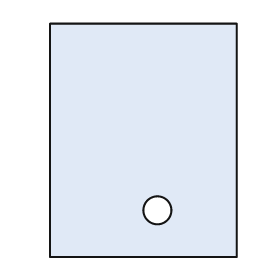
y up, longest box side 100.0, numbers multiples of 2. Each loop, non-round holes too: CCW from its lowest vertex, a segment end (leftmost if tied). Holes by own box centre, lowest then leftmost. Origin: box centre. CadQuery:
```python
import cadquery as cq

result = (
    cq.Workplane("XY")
    .moveTo(-40.0, -50.0)
    .lineTo(40.0, -50.0)
    .lineTo(40.0, 50.0)
    .lineTo(-40.0, 50.0)
    .close()
    .moveTo(6.0, -30.0)
    .circle(6.0)
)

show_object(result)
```